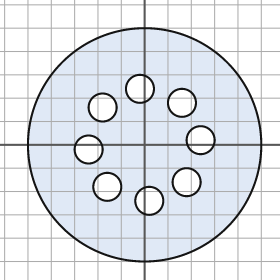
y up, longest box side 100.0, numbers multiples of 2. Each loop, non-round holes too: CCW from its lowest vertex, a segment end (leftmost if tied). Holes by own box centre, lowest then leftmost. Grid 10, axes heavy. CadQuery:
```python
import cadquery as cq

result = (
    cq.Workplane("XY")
    .moveTo(0.0, 0.0)
    .circle(50.0)
    .moveTo(2.0, -24.0)
    .circle(6.0)
    .moveTo(-16.0, -18.0)
    .circle(6.0)
    .moveTo(18.0, -16.0)
    .circle(6.0)
    .moveTo(-24.0, -2.0)
    .circle(6.0)
    .moveTo(24.0, 2.0)
    .circle(6.0)
    .moveTo(-18.0, 16.0)
    .circle(6.0)
    .moveTo(16.0, 18.0)
    .circle(6.0)
    .moveTo(-2.0, 24.0)
    .circle(6.0)
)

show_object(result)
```